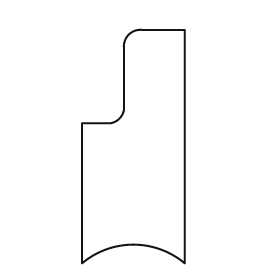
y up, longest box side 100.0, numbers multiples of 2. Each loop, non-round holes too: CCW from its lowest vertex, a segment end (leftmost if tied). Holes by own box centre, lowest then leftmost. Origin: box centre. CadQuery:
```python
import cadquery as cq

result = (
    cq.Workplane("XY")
    .moveTo(-22.0, -50.0)
    .threePointArc((0.0, -42.0), (22.0, -50.0))
    .lineTo(22.0, 50.0)
    .lineTo(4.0, 50.0)
    .threePointArc((-2.0, 48.0), (-4.0, 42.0))
    .lineTo(-4.0, 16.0)
    .threePointArc((-6.0, 12.0), (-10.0, 10.0))
    .lineTo(-22.0, 10.0)
    .close()
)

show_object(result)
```